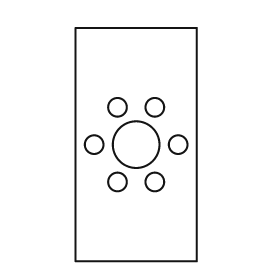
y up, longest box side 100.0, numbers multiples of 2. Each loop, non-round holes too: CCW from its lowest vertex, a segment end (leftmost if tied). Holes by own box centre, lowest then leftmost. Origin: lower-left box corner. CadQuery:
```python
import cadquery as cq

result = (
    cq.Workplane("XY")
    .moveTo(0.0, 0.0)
    .lineTo(52.0, 0.0)
    .lineTo(52.0, 100.0)
    .lineTo(0.0, 100.0)
    .close()
    .moveTo(18.0, 34.0)
    .circle(4.0)
    .moveTo(34.0, 34.0)
    .circle(4.0)
    .moveTo(8.0, 50.0)
    .circle(4.0)
    .moveTo(26.0, 50.0)
    .circle(10.0)
    .moveTo(44.0, 50.0)
    .circle(4.0)
    .moveTo(18.0, 66.0)
    .circle(4.0)
    .moveTo(34.0, 66.0)
    .circle(4.0)
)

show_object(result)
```